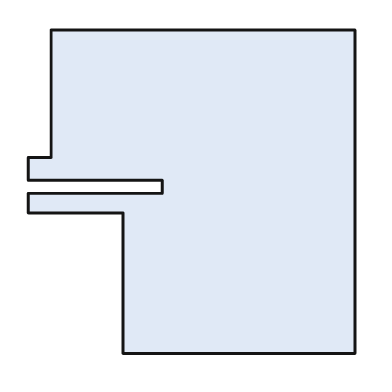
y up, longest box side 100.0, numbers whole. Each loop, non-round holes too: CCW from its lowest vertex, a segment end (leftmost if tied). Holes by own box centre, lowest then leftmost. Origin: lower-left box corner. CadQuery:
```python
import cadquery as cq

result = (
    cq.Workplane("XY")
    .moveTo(29.0, 0.0)
    .lineTo(100.0, 0.0)
    .lineTo(100.0, 99.0)
    .lineTo(7.0, 99.0)
    .lineTo(7.0, 60.0)
    .lineTo(0.0, 60.0)
    .lineTo(0.0, 53.0)
    .lineTo(41.0, 53.0)
    .lineTo(41.0, 49.0)
    .lineTo(0.0, 49.0)
    .lineTo(0.0, 43.0)
    .lineTo(29.0, 43.0)
    .close()
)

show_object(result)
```